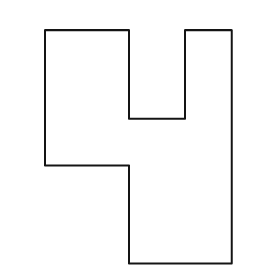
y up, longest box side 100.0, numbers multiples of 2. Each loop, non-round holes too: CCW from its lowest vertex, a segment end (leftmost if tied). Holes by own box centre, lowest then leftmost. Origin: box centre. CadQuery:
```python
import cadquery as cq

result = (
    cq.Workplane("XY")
    .moveTo(-4.0, -50.0)
    .lineTo(40.0, -50.0)
    .lineTo(40.0, 50.0)
    .lineTo(20.0, 50.0)
    .lineTo(20.0, 12.0)
    .lineTo(-4.0, 12.0)
    .lineTo(-4.0, 50.0)
    .lineTo(-40.0, 50.0)
    .lineTo(-40.0, -8.0)
    .lineTo(-4.0, -8.0)
    .close()
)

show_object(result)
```